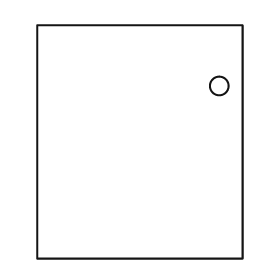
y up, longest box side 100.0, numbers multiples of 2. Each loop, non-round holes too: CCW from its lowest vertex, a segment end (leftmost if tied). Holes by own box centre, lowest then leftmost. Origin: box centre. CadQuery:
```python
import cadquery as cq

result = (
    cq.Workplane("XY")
    .moveTo(-44.0, -50.0)
    .lineTo(44.0, -50.0)
    .lineTo(44.0, 50.0)
    .lineTo(-44.0, 50.0)
    .close()
    .moveTo(34.0, 24.0)
    .circle(4.0)
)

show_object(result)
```